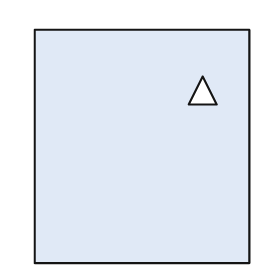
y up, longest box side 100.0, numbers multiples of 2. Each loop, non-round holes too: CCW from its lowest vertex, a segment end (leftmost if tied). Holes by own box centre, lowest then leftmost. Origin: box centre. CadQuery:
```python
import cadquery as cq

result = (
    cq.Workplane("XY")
    .moveTo(-46.0, -50.0)
    .lineTo(46.0, -50.0)
    .lineTo(46.0, 50.0)
    .lineTo(-46.0, 50.0)
    .close()
    .moveTo(20.0, 18.0)
    .lineTo(32.0, 18.0)
    .lineTo(26.0, 30.0)
    .close()
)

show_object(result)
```